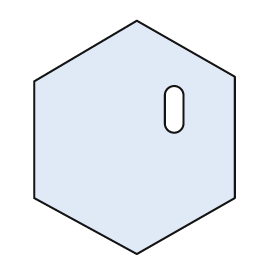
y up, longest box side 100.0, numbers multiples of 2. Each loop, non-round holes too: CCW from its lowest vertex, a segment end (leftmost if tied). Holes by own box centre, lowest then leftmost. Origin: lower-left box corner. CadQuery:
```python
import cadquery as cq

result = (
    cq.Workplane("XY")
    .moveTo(44.0, 0.0)
    .lineTo(86.0, 24.0)
    .lineTo(86.0, 76.0)
    .lineTo(44.0, 100.0)
    .lineTo(0.0, 74.0)
    .lineTo(0.0, 24.0)
    .close()
    .moveTo(56.0, 56.0)
    .threePointArc((60.0, 52.0), (64.0, 56.0))
    .lineTo(64.0, 68.0)
    .threePointArc((60.0, 72.0), (56.0, 68.0))
    .close()
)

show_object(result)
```